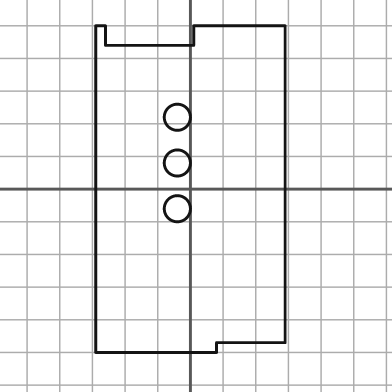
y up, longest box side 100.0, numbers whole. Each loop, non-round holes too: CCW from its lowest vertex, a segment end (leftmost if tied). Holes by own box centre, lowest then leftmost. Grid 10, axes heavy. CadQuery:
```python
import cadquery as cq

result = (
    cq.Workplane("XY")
    .moveTo(-29.0, -50.0)
    .lineTo(8.0, -50.0)
    .lineTo(8.0, -47.0)
    .lineTo(29.0, -47.0)
    .lineTo(29.0, 50.0)
    .lineTo(1.0, 50.0)
    .lineTo(1.0, 44.0)
    .lineTo(-26.0, 44.0)
    .lineTo(-26.0, 50.0)
    .lineTo(-29.0, 50.0)
    .close()
    .moveTo(-4.0, -6.0)
    .circle(4.0)
    .moveTo(-4.0, 8.0)
    .circle(4.0)
    .moveTo(-4.0, 22.0)
    .circle(4.0)
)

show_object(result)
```